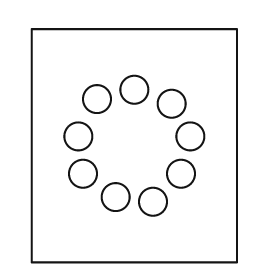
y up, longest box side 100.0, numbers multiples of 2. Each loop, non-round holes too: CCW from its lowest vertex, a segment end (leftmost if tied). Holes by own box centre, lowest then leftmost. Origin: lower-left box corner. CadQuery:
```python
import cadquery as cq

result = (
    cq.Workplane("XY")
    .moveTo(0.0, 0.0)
    .lineTo(88.0, 0.0)
    .lineTo(88.0, 100.0)
    .lineTo(0.0, 100.0)
    .close()
    .moveTo(52.0, 26.0)
    .circle(6.0)
    .moveTo(36.0, 28.0)
    .circle(6.0)
    .moveTo(22.0, 38.0)
    .circle(6.0)
    .moveTo(64.0, 38.0)
    .circle(6.0)
    .moveTo(20.0, 54.0)
    .circle(6.0)
    .moveTo(68.0, 54.0)
    .circle(6.0)
    .moveTo(60.0, 68.0)
    .circle(6.0)
    .moveTo(28.0, 70.0)
    .circle(6.0)
    .moveTo(44.0, 74.0)
    .circle(6.0)
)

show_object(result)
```